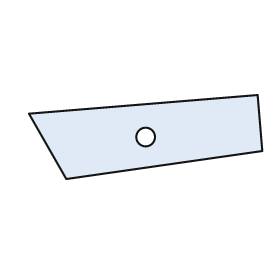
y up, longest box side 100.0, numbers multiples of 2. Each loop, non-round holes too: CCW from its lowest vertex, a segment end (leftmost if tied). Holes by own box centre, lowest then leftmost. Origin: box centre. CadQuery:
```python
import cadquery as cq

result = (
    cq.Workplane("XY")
    .moveTo(-34.0, -18.0)
    .lineTo(50.0, -6.0)
    .lineTo(48.0, 18.0)
    .lineTo(-50.0, 10.0)
    .close()
    .moveTo(0.0, 0.0)
    .circle(4.0)
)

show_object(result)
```